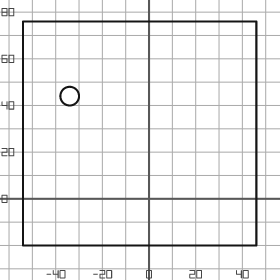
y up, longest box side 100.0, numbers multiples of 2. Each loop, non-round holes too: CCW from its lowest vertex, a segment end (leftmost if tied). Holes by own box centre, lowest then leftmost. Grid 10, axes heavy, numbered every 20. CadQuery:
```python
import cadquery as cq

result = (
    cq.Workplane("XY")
    .moveTo(-54.0, -20.0)
    .lineTo(46.0, -20.0)
    .lineTo(46.0, 76.0)
    .lineTo(-54.0, 76.0)
    .close()
    .moveTo(-34.0, 44.0)
    .circle(4.0)
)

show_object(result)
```